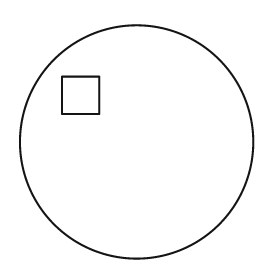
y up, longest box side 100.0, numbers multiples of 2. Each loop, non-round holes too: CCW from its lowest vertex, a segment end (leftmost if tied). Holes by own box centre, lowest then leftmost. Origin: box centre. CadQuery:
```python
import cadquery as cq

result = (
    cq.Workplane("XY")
    .moveTo(0.0, 0.0)
    .circle(50.0)
    .moveTo(-32.0, 12.0)
    .lineTo(-16.0, 12.0)
    .lineTo(-16.0, 28.0)
    .lineTo(-32.0, 28.0)
    .close()
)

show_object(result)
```